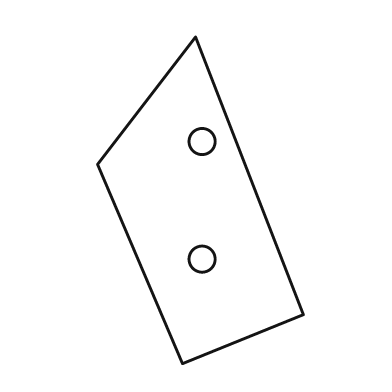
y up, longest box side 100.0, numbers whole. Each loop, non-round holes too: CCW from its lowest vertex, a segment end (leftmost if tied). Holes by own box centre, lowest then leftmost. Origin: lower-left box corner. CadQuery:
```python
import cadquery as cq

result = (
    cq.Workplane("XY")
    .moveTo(26.0, 0.0)
    .lineTo(63.0, 15.0)
    .lineTo(30.0, 100.0)
    .lineTo(0.0, 61.0)
    .close()
    .moveTo(32.0, 32.0)
    .circle(4.0)
    .moveTo(32.0, 68.0)
    .circle(4.0)
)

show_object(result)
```